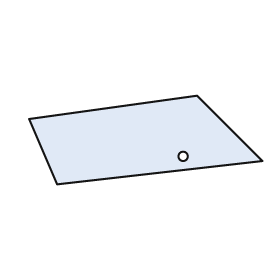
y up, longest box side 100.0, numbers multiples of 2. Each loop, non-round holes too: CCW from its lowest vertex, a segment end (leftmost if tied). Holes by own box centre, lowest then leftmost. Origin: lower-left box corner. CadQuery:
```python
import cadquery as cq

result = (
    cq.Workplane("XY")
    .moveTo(12.0, 0.0)
    .lineTo(100.0, 10.0)
    .lineTo(72.0, 38.0)
    .lineTo(0.0, 28.0)
    .close()
    .moveTo(66.0, 12.0)
    .circle(2.0)
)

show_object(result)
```